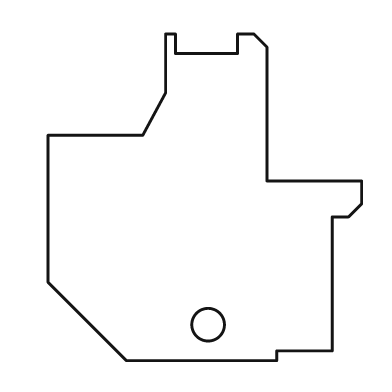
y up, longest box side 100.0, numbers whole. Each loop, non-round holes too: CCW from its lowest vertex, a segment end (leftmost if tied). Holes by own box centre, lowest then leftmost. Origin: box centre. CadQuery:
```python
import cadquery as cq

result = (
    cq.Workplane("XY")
    .moveTo(-24.0, -50.0)
    .lineTo(22.0, -50.0)
    .lineTo(22.0, -47.0)
    .lineTo(39.0, -47.0)
    .lineTo(39.0, -6.0)
    .lineTo(44.0, -6.0)
    .lineTo(48.0, -2.0)
    .lineTo(48.0, 5.0)
    .lineTo(19.0, 5.0)
    .lineTo(19.0, 46.0)
    .lineTo(15.0, 50.0)
    .lineTo(10.0, 50.0)
    .lineTo(10.0, 44.0)
    .lineTo(-9.0, 44.0)
    .lineTo(-9.0, 50.0)
    .lineTo(-12.0, 50.0)
    .lineTo(-12.0, 32.0)
    .lineTo(-19.0, 19.0)
    .lineTo(-48.0, 19.0)
    .lineTo(-48.0, -26.0)
    .close()
    .moveTo(1.0, -39.0)
    .circle(5.0)
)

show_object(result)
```